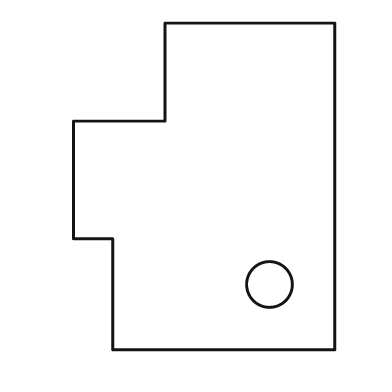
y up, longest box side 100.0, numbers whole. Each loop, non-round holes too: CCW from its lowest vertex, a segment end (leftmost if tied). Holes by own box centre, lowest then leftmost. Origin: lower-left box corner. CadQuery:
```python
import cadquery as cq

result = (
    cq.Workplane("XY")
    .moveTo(12.0, 0.0)
    .lineTo(80.0, 0.0)
    .lineTo(80.0, 100.0)
    .lineTo(28.0, 100.0)
    .lineTo(28.0, 70.0)
    .lineTo(0.0, 70.0)
    .lineTo(0.0, 34.0)
    .lineTo(12.0, 34.0)
    .close()
    .moveTo(60.0, 20.0)
    .circle(7.0)
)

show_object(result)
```